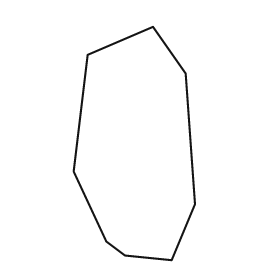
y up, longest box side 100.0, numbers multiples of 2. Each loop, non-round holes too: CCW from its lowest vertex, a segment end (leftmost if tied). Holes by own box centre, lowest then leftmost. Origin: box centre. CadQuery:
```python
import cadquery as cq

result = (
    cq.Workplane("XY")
    .moveTo(16.0, -50.0)
    .lineTo(26.0, -26.0)
    .lineTo(22.0, 30.0)
    .lineTo(8.0, 50.0)
    .lineTo(-20.0, 38.0)
    .lineTo(-26.0, -12.0)
    .lineTo(-12.0, -42.0)
    .lineTo(-4.0, -48.0)
    .close()
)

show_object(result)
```